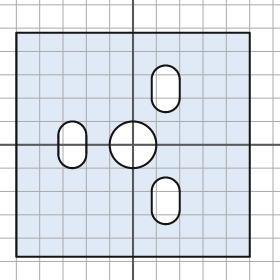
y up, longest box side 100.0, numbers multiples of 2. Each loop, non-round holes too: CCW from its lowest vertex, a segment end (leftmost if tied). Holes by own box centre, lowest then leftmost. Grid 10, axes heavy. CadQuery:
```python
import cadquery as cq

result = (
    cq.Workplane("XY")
    .moveTo(-50.0, -48.0)
    .lineTo(50.0, -48.0)
    .lineTo(50.0, 48.0)
    .lineTo(-50.0, 48.0)
    .close()
    .moveTo(8.0, -28.0)
    .threePointArc((14.0, -34.0), (20.0, -28.0))
    .lineTo(20.0, -20.0)
    .threePointArc((14.0, -14.0), (8.0, -20.0))
    .close()
    .moveTo(-32.0, -4.0)
    .threePointArc((-26.0, -10.0), (-20.0, -4.0))
    .lineTo(-20.0, 4.0)
    .threePointArc((-26.0, 10.0), (-32.0, 4.0))
    .close()
    .moveTo(0.0, 0.0)
    .circle(10.0)
    .moveTo(8.0, 20.0)
    .threePointArc((14.0, 14.0), (20.0, 20.0))
    .lineTo(20.0, 28.0)
    .threePointArc((14.0, 34.0), (8.0, 28.0))
    .close()
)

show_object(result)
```